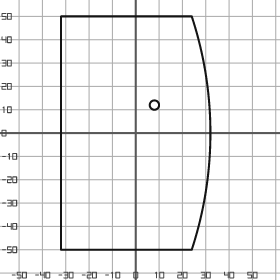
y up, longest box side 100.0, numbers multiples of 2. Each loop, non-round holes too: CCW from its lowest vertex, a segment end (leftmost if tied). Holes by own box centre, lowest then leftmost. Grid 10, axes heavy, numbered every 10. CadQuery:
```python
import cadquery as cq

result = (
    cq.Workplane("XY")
    .moveTo(-32.0, -50.0)
    .lineTo(24.0, -50.0)
    .threePointArc((32.0, 0.0), (24.0, 50.0))
    .lineTo(-32.0, 50.0)
    .close()
    .moveTo(8.0, 12.0)
    .circle(2.0)
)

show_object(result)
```